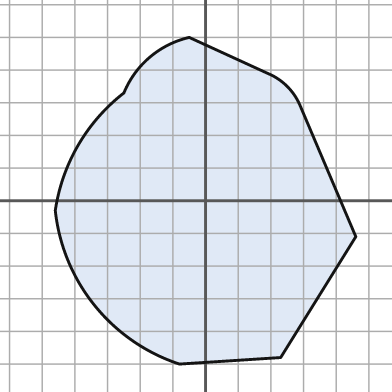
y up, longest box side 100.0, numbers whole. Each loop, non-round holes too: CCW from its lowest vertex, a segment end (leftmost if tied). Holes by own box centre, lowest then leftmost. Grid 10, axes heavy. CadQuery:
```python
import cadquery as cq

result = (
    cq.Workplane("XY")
    .moveTo(-8.0, -50.0)
    .lineTo(23.0, -48.0)
    .lineTo(46.0, -11.0)
    .lineTo(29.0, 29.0)
    .threePointArc((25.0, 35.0), (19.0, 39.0))
    .lineTo(-5.0, 50.0)
    .threePointArc((-17.0, 44.0), (-25.0, 33.0))
    .threePointArc((-39.0, 17.0), (-46.0, -3.0))
    .threePointArc((-34.0, -32.0), (-8.0, -50.0))
    .close()
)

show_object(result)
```